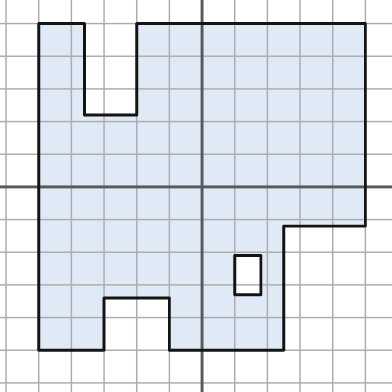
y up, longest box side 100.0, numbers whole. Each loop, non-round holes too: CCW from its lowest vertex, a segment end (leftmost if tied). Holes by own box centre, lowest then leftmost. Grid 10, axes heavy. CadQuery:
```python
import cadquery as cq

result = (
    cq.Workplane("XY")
    .moveTo(-50.0, -50.0)
    .lineTo(-30.0, -50.0)
    .lineTo(-30.0, -34.0)
    .lineTo(-10.0, -34.0)
    .lineTo(-10.0, -50.0)
    .lineTo(25.0, -50.0)
    .lineTo(25.0, -12.0)
    .lineTo(50.0, -12.0)
    .lineTo(50.0, 50.0)
    .lineTo(-20.0, 50.0)
    .lineTo(-20.0, 22.0)
    .lineTo(-36.0, 22.0)
    .lineTo(-36.0, 50.0)
    .lineTo(-50.0, 50.0)
    .close()
    .moveTo(10.0, -33.0)
    .lineTo(18.0, -33.0)
    .lineTo(18.0, -21.0)
    .lineTo(10.0, -21.0)
    .close()
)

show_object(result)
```